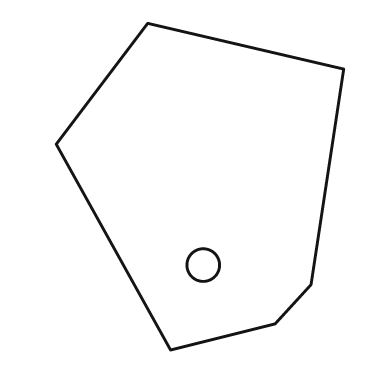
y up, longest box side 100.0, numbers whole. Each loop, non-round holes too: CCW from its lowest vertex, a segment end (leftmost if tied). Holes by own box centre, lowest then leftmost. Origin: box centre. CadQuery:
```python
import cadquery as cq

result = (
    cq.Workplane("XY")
    .moveTo(-9.0, -50.0)
    .lineTo(23.0, -42.0)
    .lineTo(34.0, -30.0)
    .lineTo(44.0, 36.0)
    .lineTo(-16.0, 50.0)
    .lineTo(-44.0, 13.0)
    .close()
    .moveTo(1.0, -24.0)
    .circle(5.0)
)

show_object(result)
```